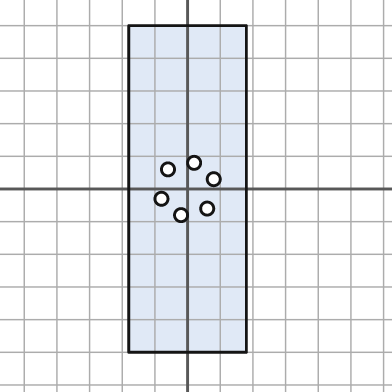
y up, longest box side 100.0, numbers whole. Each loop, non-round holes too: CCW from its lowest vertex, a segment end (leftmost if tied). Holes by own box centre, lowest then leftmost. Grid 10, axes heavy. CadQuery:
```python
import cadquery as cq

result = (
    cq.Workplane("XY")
    .moveTo(-18.0, -50.0)
    .lineTo(18.0, -50.0)
    .lineTo(18.0, 50.0)
    .lineTo(-18.0, 50.0)
    .close()
    .moveTo(-2.0, -8.0)
    .circle(2.0)
    .moveTo(6.0, -6.0)
    .circle(2.0)
    .moveTo(-8.0, -3.0)
    .circle(2.0)
    .moveTo(8.0, 3.0)
    .circle(2.0)
    .moveTo(-6.0, 6.0)
    .circle(2.0)
    .moveTo(2.0, 8.0)
    .circle(2.0)
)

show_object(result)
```